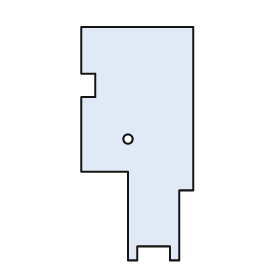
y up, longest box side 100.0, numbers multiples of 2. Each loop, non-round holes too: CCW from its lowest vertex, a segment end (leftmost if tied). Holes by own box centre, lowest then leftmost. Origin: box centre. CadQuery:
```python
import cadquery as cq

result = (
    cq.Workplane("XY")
    .moveTo(-4.0, -50.0)
    .lineTo(0.0, -50.0)
    .lineTo(0.0, -44.0)
    .lineTo(14.0, -44.0)
    .lineTo(14.0, -50.0)
    .lineTo(18.0, -50.0)
    .lineTo(18.0, -20.0)
    .lineTo(24.0, -20.0)
    .lineTo(24.0, 50.0)
    .lineTo(-24.0, 50.0)
    .lineTo(-24.0, 30.0)
    .lineTo(-18.0, 30.0)
    .lineTo(-18.0, 20.0)
    .lineTo(-24.0, 20.0)
    .lineTo(-24.0, -12.0)
    .lineTo(-4.0, -12.0)
    .close()
    .moveTo(-4.0, 2.0)
    .circle(2.0)
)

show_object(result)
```